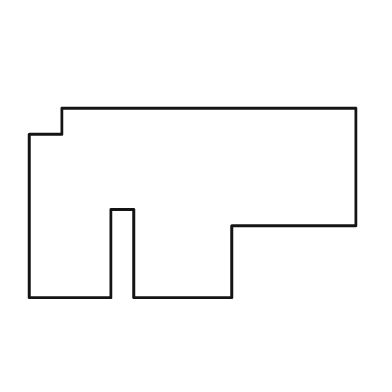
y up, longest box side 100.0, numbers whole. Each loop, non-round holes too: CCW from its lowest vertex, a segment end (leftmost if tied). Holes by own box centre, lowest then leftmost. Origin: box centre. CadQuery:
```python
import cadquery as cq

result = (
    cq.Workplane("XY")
    .moveTo(-50.0, -29.0)
    .lineTo(-25.0, -29.0)
    .lineTo(-25.0, -2.0)
    .lineTo(-18.0, -2.0)
    .lineTo(-18.0, -29.0)
    .lineTo(12.0, -29.0)
    .lineTo(12.0, -7.0)
    .lineTo(50.0, -7.0)
    .lineTo(50.0, 29.0)
    .lineTo(-40.0, 29.0)
    .lineTo(-40.0, 21.0)
    .lineTo(-50.0, 21.0)
    .close()
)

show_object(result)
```